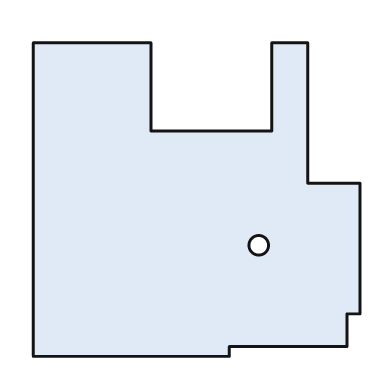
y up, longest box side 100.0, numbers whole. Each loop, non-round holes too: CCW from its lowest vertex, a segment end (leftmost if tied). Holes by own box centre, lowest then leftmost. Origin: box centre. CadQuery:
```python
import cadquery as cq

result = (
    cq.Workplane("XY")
    .moveTo(-50.0, -48.0)
    .lineTo(10.0, -48.0)
    .lineTo(10.0, -45.0)
    .lineTo(46.0, -45.0)
    .lineTo(46.0, -35.0)
    .lineTo(50.0, -35.0)
    .lineTo(50.0, 5.0)
    .lineTo(34.0, 5.0)
    .lineTo(34.0, 48.0)
    .lineTo(23.0, 48.0)
    .lineTo(23.0, 21.0)
    .lineTo(-14.0, 21.0)
    .lineTo(-14.0, 48.0)
    .lineTo(-50.0, 48.0)
    .close()
    .moveTo(19.0, -14.0)
    .circle(3.0)
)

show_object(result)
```